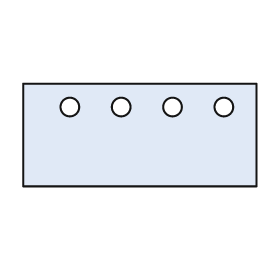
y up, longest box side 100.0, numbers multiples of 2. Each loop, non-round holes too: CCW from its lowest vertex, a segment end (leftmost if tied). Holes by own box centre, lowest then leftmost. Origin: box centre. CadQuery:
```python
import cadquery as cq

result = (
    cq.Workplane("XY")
    .moveTo(-50.0, -22.0)
    .lineTo(50.0, -22.0)
    .lineTo(50.0, 22.0)
    .lineTo(-50.0, 22.0)
    .close()
    .moveTo(-30.0, 12.0)
    .circle(4.0)
    .moveTo(-8.0, 12.0)
    .circle(4.0)
    .moveTo(14.0, 12.0)
    .circle(4.0)
    .moveTo(36.0, 12.0)
    .circle(4.0)
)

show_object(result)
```